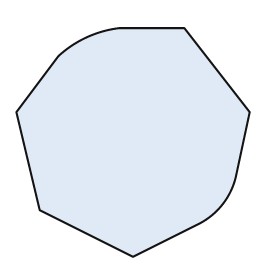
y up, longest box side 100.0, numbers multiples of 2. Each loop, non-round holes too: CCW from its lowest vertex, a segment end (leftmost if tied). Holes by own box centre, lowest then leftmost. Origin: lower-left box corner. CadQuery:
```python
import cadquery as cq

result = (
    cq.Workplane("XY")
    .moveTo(50.0, 0.0)
    .lineTo(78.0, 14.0)
    .threePointArc((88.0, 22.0), (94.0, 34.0))
    .lineTo(100.0, 62.0)
    .lineTo(72.0, 98.0)
    .lineTo(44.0, 98.0)
    .threePointArc((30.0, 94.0), (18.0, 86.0))
    .lineTo(0.0, 62.0)
    .lineTo(10.0, 20.0)
    .close()
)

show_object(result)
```